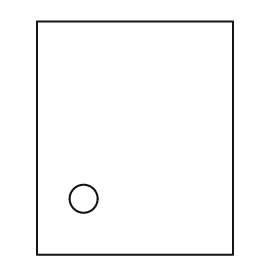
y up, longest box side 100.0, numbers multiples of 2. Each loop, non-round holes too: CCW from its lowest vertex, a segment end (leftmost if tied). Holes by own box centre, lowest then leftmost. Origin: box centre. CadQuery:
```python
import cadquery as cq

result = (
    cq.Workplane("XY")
    .moveTo(-42.0, -50.0)
    .lineTo(42.0, -50.0)
    .lineTo(42.0, 50.0)
    .lineTo(-42.0, 50.0)
    .close()
    .moveTo(-22.0, -26.0)
    .circle(6.0)
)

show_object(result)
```